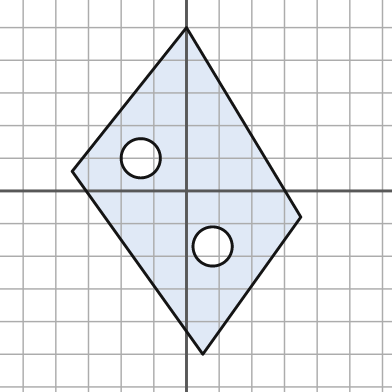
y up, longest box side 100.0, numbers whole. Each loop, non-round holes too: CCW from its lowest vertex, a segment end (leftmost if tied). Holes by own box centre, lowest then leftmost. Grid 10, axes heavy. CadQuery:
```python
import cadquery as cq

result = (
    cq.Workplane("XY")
    .moveTo(5.0, -50.0)
    .lineTo(35.0, -8.0)
    .lineTo(0.0, 50.0)
    .lineTo(-35.0, 6.0)
    .close()
    .moveTo(8.0, -17.0)
    .circle(6.0)
    .moveTo(-14.0, 10.0)
    .circle(6.0)
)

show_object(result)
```